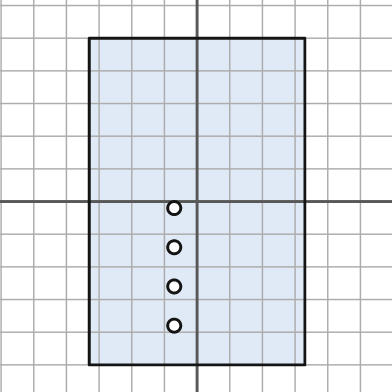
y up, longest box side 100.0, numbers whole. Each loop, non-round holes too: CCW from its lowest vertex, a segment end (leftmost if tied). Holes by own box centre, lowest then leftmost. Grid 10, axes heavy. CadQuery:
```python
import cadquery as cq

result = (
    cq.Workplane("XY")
    .moveTo(-33.0, -50.0)
    .lineTo(33.0, -50.0)
    .lineTo(33.0, 50.0)
    .lineTo(-33.0, 50.0)
    .close()
    .moveTo(-7.0, -38.0)
    .circle(2.0)
    .moveTo(-7.0, -26.0)
    .circle(2.0)
    .moveTo(-7.0, -14.0)
    .circle(2.0)
    .moveTo(-7.0, -2.0)
    .circle(2.0)
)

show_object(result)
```